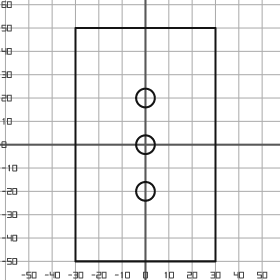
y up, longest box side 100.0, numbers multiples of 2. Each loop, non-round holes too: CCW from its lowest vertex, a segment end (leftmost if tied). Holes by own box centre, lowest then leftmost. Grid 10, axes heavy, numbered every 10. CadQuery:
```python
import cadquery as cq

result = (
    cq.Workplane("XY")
    .moveTo(-30.0, -50.0)
    .lineTo(30.0, -50.0)
    .lineTo(30.0, 50.0)
    .lineTo(-30.0, 50.0)
    .close()
    .moveTo(0.0, -20.0)
    .circle(4.0)
    .moveTo(0.0, 0.0)
    .circle(4.0)
    .moveTo(0.0, 20.0)
    .circle(4.0)
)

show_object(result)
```